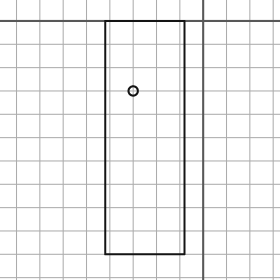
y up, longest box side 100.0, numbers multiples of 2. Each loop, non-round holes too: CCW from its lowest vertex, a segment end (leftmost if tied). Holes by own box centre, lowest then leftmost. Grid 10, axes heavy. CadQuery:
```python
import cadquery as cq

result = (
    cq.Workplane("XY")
    .moveTo(-42.0, -100.0)
    .lineTo(-8.0, -100.0)
    .lineTo(-8.0, 0.0)
    .lineTo(-42.0, 0.0)
    .close()
    .moveTo(-30.0, -30.0)
    .circle(2.0)
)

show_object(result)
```